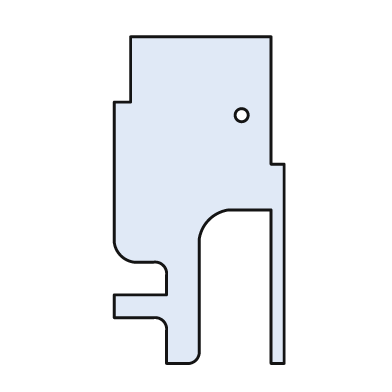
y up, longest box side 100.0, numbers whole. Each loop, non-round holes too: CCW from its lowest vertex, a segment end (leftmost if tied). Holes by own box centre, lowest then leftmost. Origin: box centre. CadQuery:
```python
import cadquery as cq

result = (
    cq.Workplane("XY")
    .moveTo(-10.0, -50.0)
    .lineTo(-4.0, -50.0)
    .threePointArc((-1.0, -49.0), (0.0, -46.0))
    .lineTo(0.0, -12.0)
    .threePointArc((3.0, -6.0), (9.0, -3.0))
    .lineTo(22.0, -3.0)
    .lineTo(22.0, -50.0)
    .lineTo(26.0, -50.0)
    .lineTo(26.0, 11.0)
    .lineTo(22.0, 11.0)
    .lineTo(22.0, 50.0)
    .lineTo(-21.0, 50.0)
    .lineTo(-21.0, 30.0)
    .lineTo(-26.0, 30.0)
    .lineTo(-26.0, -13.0)
    .threePointArc((-24.0, -17.0), (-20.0, -19.0))
    .lineTo(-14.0, -19.0)
    .threePointArc((-11.0, -20.0), (-10.0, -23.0))
    .lineTo(-10.0, -29.0)
    .lineTo(-26.0, -29.0)
    .lineTo(-26.0, -36.0)
    .lineTo(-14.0, -36.0)
    .threePointArc((-11.0, -37.0), (-10.0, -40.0))
    .close()
    .moveTo(13.0, 26.0)
    .circle(2.0)
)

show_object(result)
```